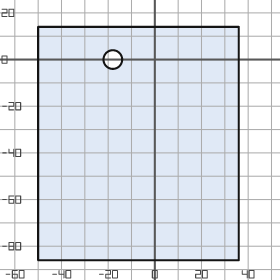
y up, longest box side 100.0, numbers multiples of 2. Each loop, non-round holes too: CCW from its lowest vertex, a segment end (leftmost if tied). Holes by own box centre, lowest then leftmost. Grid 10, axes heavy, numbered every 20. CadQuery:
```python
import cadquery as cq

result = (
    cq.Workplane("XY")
    .moveTo(-50.0, -86.0)
    .lineTo(36.0, -86.0)
    .lineTo(36.0, 14.0)
    .lineTo(-50.0, 14.0)
    .close()
    .moveTo(-18.0, 0.0)
    .circle(4.0)
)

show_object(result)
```